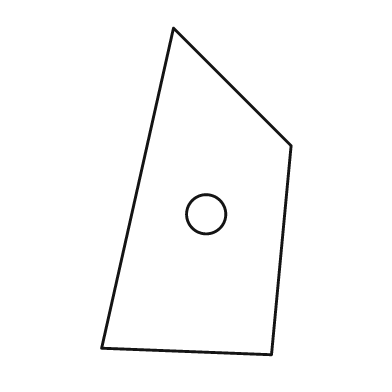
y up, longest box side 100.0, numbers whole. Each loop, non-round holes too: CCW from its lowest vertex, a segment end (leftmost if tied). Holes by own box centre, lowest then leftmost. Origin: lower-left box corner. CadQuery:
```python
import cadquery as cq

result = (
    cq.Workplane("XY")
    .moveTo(52.0, 0.0)
    .lineTo(58.0, 64.0)
    .lineTo(22.0, 100.0)
    .lineTo(0.0, 2.0)
    .close()
    .moveTo(32.0, 43.0)
    .circle(6.0)
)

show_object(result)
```